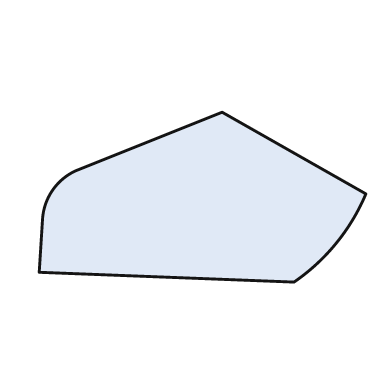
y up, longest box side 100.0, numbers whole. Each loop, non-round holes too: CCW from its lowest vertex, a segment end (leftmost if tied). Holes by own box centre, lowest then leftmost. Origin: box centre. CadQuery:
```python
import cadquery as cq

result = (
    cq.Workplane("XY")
    .moveTo(28.0, -26.0)
    .threePointArc((41.0, -14.0), (50.0, 1.0))
    .lineTo(6.0, 26.0)
    .lineTo(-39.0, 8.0)
    .threePointArc((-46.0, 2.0), (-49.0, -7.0))
    .lineTo(-50.0, -23.0)
    .close()
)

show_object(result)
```